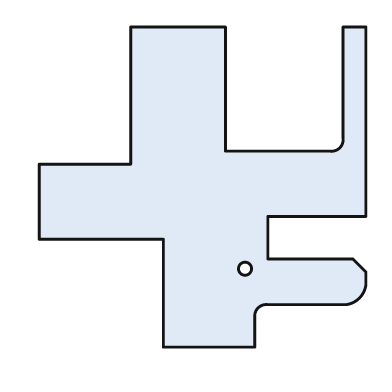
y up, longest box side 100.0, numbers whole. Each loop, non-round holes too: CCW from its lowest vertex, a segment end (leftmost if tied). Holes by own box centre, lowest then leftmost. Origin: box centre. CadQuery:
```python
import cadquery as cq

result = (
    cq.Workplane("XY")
    .moveTo(-12.0, -49.0)
    .lineTo(16.0, -49.0)
    .lineTo(16.0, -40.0)
    .threePointArc((17.0, -37.0), (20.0, -36.0))
    .lineTo(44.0, -36.0)
    .threePointArc((48.0, -34.0), (50.0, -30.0))
    .lineTo(50.0, -26.0)
    .lineTo(46.0, -22.0)
    .lineTo(20.0, -22.0)
    .lineTo(20.0, -9.0)
    .lineTo(50.0, -9.0)
    .lineTo(50.0, 49.0)
    .lineTo(43.0, 49.0)
    .lineTo(43.0, 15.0)
    .threePointArc((42.0, 12.0), (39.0, 11.0))
    .lineTo(7.0, 11.0)
    .lineTo(7.0, 49.0)
    .lineTo(-22.0, 49.0)
    .lineTo(-22.0, 7.0)
    .lineTo(-50.0, 7.0)
    .lineTo(-50.0, -16.0)
    .lineTo(-12.0, -16.0)
    .close()
    .moveTo(13.0, -25.0)
    .circle(2.0)
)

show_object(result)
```